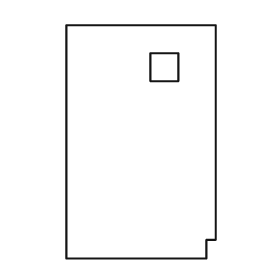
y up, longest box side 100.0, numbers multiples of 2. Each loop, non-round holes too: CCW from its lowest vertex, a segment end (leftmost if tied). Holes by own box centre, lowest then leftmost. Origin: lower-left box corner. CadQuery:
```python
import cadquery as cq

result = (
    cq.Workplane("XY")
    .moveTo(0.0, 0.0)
    .lineTo(60.0, 0.0)
    .lineTo(60.0, 8.0)
    .lineTo(64.0, 8.0)
    .lineTo(64.0, 100.0)
    .lineTo(0.0, 100.0)
    .close()
    .moveTo(36.0, 76.0)
    .lineTo(48.0, 76.0)
    .lineTo(48.0, 88.0)
    .lineTo(36.0, 88.0)
    .close()
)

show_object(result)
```